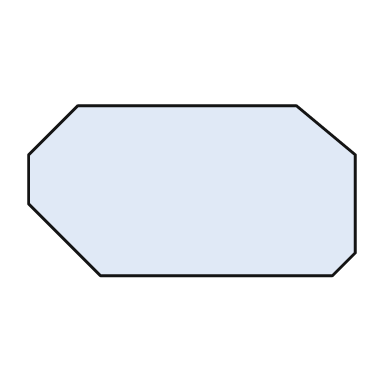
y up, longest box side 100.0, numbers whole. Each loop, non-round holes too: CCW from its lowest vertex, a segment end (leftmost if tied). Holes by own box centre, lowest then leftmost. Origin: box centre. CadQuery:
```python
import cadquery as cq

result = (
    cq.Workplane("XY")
    .moveTo(-28.0, -26.0)
    .lineTo(43.0, -26.0)
    .lineTo(50.0, -19.0)
    .lineTo(50.0, 11.0)
    .lineTo(32.0, 26.0)
    .lineTo(-35.0, 26.0)
    .lineTo(-50.0, 11.0)
    .lineTo(-50.0, -4.0)
    .close()
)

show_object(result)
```